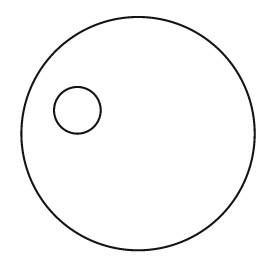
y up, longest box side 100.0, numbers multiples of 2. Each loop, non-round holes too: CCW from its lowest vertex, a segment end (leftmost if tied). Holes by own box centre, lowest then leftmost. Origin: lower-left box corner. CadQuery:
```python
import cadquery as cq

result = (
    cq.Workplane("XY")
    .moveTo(50.0, 50.0)
    .circle(50.0)
    .moveTo(24.0, 60.0)
    .circle(10.0)
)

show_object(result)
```